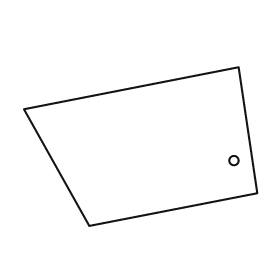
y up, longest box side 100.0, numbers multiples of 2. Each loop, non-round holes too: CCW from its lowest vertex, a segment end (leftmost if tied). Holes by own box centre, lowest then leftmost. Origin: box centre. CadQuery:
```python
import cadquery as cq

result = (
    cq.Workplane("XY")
    .moveTo(-22.0, -34.0)
    .lineTo(50.0, -20.0)
    .lineTo(42.0, 34.0)
    .lineTo(-50.0, 16.0)
    .close()
    .moveTo(40.0, -6.0)
    .circle(2.0)
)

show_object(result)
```